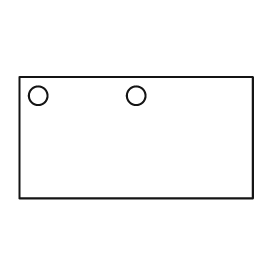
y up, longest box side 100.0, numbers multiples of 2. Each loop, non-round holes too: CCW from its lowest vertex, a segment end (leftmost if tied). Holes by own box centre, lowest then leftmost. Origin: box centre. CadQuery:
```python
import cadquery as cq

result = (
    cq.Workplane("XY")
    .moveTo(-50.0, -26.0)
    .lineTo(50.0, -26.0)
    .lineTo(50.0, 26.0)
    .lineTo(-50.0, 26.0)
    .close()
    .moveTo(-42.0, 18.0)
    .circle(4.0)
    .moveTo(0.0, 18.0)
    .circle(4.0)
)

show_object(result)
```